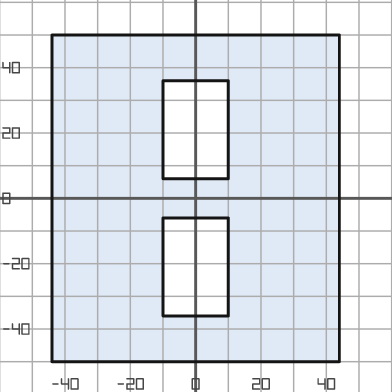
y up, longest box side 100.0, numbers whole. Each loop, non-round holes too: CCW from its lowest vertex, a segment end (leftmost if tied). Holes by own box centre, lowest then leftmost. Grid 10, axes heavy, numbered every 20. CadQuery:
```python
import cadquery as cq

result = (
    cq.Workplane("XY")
    .moveTo(-44.0, -50.0)
    .lineTo(44.0, -50.0)
    .lineTo(44.0, 50.0)
    .lineTo(-44.0, 50.0)
    .close()
    .moveTo(-10.0, -36.0)
    .lineTo(10.0, -36.0)
    .lineTo(10.0, -6.0)
    .lineTo(-10.0, -6.0)
    .close()
    .moveTo(-10.0, 6.0)
    .lineTo(10.0, 6.0)
    .lineTo(10.0, 36.0)
    .lineTo(-10.0, 36.0)
    .close()
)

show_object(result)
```